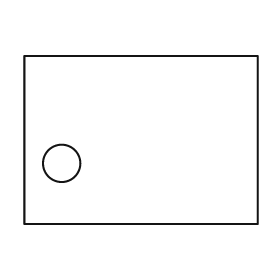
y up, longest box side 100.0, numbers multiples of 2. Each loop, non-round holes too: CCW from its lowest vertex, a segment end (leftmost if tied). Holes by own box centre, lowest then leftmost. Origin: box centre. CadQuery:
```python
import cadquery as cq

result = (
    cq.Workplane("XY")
    .moveTo(-50.0, -36.0)
    .lineTo(50.0, -36.0)
    .lineTo(50.0, 36.0)
    .lineTo(-50.0, 36.0)
    .close()
    .moveTo(-34.0, -10.0)
    .circle(8.0)
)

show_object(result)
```